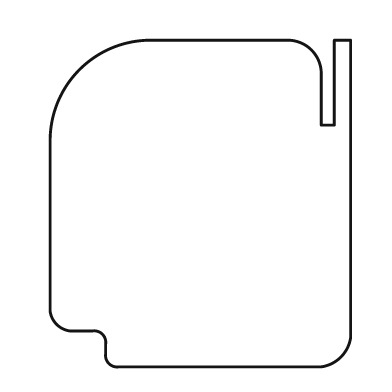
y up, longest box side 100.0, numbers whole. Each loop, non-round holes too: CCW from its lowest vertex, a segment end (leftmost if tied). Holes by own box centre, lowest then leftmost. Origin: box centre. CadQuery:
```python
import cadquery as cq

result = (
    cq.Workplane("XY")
    .moveTo(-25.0, -50.0)
    .lineTo(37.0, -50.0)
    .threePointArc((43.0, -47.0), (46.0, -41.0))
    .lineTo(46.0, 50.0)
    .lineTo(41.0, 50.0)
    .lineTo(41.0, 24.0)
    .lineTo(37.0, 24.0)
    .lineTo(37.0, 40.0)
    .threePointArc((34.0, 47.0), (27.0, 50.0))
    .lineTo(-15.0, 50.0)
    .threePointArc((-37.0, 41.0), (-46.0, 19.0))
    .lineTo(-46.0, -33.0)
    .threePointArc((-44.0, -37.0), (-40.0, -39.0))
    .lineTo(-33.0, -39.0)
    .threePointArc((-30.0, -40.0), (-29.0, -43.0))
    .lineTo(-29.0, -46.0)
    .threePointArc((-28.0, -49.0), (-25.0, -50.0))
    .close()
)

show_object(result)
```